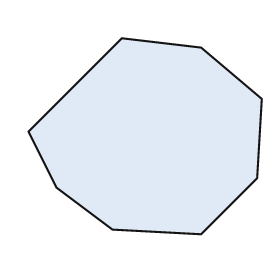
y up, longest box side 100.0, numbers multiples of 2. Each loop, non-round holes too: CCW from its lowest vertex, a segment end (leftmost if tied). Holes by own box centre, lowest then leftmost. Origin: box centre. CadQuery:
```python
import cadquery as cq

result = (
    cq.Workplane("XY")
    .moveTo(24.0, -42.0)
    .lineTo(48.0, -18.0)
    .lineTo(50.0, 16.0)
    .lineTo(24.0, 38.0)
    .lineTo(-10.0, 42.0)
    .lineTo(-50.0, 2.0)
    .lineTo(-38.0, -22.0)
    .lineTo(-14.0, -40.0)
    .close()
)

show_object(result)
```